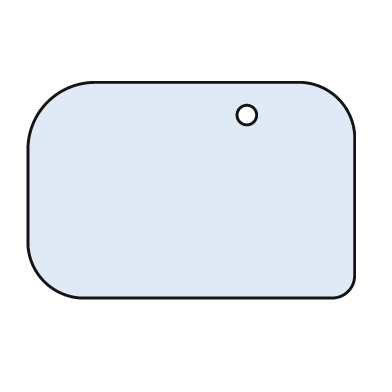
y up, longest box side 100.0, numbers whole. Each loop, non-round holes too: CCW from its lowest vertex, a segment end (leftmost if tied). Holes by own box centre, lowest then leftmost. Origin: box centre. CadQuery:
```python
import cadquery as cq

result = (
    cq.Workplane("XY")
    .moveTo(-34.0, -33.0)
    .lineTo(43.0, -33.0)
    .threePointArc((48.0, -31.0), (50.0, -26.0))
    .lineTo(50.0, 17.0)
    .threePointArc((45.0, 28.0), (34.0, 33.0))
    .lineTo(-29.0, 33.0)
    .threePointArc((-44.0, 27.0), (-50.0, 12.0))
    .lineTo(-50.0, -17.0)
    .threePointArc((-45.0, -28.0), (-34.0, -33.0))
    .close()
    .moveTo(17.0, 23.0)
    .circle(3.0)
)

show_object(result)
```